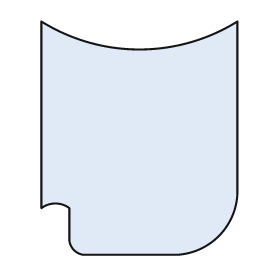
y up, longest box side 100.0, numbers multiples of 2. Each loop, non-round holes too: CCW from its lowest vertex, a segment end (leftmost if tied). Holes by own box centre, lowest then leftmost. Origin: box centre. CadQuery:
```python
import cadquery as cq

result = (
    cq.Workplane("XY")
    .moveTo(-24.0, -50.0)
    .lineTo(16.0, -50.0)
    .threePointArc((34.0, -42.0), (42.0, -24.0))
    .lineTo(42.0, 50.0)
    .threePointArc((0.0, 38.0), (-42.0, 50.0))
    .lineTo(-42.0, -30.0)
    .threePointArc((-36.0, -28.0), (-30.0, -30.0))
    .lineTo(-30.0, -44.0)
    .threePointArc((-28.0, -48.0), (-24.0, -50.0))
    .close()
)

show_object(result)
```